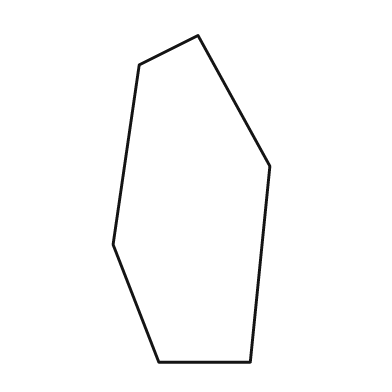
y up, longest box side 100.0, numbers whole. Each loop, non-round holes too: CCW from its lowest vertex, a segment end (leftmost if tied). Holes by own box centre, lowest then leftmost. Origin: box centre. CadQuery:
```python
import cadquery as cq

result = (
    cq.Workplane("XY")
    .moveTo(-10.0, -50.0)
    .lineTo(18.0, -50.0)
    .lineTo(24.0, 10.0)
    .lineTo(2.0, 50.0)
    .lineTo(-16.0, 41.0)
    .lineTo(-24.0, -14.0)
    .close()
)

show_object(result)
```